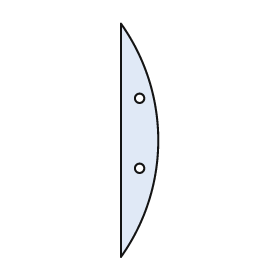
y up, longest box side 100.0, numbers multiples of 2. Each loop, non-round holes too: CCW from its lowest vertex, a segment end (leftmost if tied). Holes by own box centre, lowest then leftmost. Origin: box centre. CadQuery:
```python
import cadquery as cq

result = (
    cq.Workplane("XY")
    .moveTo(-8.0, -50.0)
    .threePointArc((8.0, 0.0), (-8.0, 50.0))
    .close()
    .moveTo(0.0, -12.0)
    .circle(2.0)
    .moveTo(0.0, 18.0)
    .circle(2.0)
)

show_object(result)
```